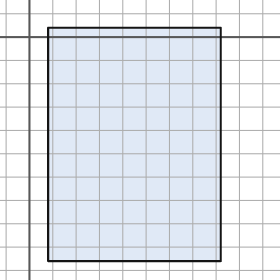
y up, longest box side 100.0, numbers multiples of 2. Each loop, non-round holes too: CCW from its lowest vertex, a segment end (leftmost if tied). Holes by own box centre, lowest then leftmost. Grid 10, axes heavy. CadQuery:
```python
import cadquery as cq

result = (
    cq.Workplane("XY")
    .moveTo(8.0, -96.0)
    .lineTo(82.0, -96.0)
    .lineTo(82.0, 4.0)
    .lineTo(8.0, 4.0)
    .close()
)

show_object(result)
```